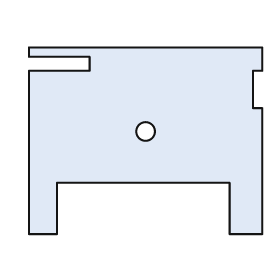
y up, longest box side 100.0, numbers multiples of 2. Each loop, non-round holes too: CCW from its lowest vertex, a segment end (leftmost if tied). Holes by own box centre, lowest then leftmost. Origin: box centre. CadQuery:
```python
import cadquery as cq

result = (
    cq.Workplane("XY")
    .moveTo(-50.0, -40.0)
    .lineTo(-38.0, -40.0)
    .lineTo(-38.0, -18.0)
    .lineTo(36.0, -18.0)
    .lineTo(36.0, -40.0)
    .lineTo(50.0, -40.0)
    .lineTo(50.0, 14.0)
    .lineTo(46.0, 14.0)
    .lineTo(46.0, 30.0)
    .lineTo(50.0, 30.0)
    .lineTo(50.0, 40.0)
    .lineTo(-50.0, 40.0)
    .lineTo(-50.0, 36.0)
    .lineTo(-24.0, 36.0)
    .lineTo(-24.0, 30.0)
    .lineTo(-50.0, 30.0)
    .close()
    .moveTo(0.0, 4.0)
    .circle(4.0)
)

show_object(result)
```